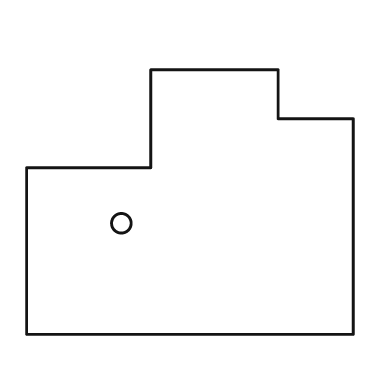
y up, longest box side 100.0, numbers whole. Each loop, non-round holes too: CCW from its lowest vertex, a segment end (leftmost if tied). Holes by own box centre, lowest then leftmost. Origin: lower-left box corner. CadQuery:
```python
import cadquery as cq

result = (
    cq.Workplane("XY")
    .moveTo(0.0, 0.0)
    .lineTo(100.0, 0.0)
    .lineTo(100.0, 66.0)
    .lineTo(77.0, 66.0)
    .lineTo(77.0, 81.0)
    .lineTo(38.0, 81.0)
    .lineTo(38.0, 51.0)
    .lineTo(0.0, 51.0)
    .close()
    .moveTo(29.0, 34.0)
    .circle(3.0)
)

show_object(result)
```